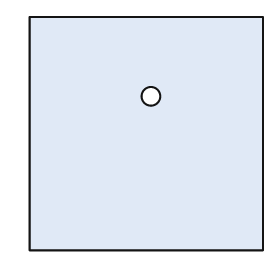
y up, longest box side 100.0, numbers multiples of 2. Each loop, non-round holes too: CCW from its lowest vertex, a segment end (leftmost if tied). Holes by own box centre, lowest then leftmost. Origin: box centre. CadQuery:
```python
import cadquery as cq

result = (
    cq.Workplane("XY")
    .moveTo(-50.0, -50.0)
    .lineTo(50.0, -50.0)
    .lineTo(50.0, 50.0)
    .lineTo(-50.0, 50.0)
    .close()
    .moveTo(2.0, 16.0)
    .circle(4.0)
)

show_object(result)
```